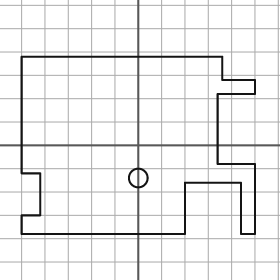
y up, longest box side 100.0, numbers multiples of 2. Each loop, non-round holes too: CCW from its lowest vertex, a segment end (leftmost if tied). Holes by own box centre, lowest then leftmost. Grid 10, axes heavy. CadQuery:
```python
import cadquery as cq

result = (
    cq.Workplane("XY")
    .moveTo(-50.0, -38.0)
    .lineTo(20.0, -38.0)
    .lineTo(20.0, -16.0)
    .lineTo(44.0, -16.0)
    .lineTo(44.0, -38.0)
    .lineTo(50.0, -38.0)
    .lineTo(50.0, -8.0)
    .lineTo(34.0, -8.0)
    .lineTo(34.0, 22.0)
    .lineTo(50.0, 22.0)
    .lineTo(50.0, 28.0)
    .lineTo(36.0, 28.0)
    .lineTo(36.0, 38.0)
    .lineTo(-50.0, 38.0)
    .lineTo(-50.0, -12.0)
    .lineTo(-42.0, -12.0)
    .lineTo(-42.0, -30.0)
    .lineTo(-50.0, -30.0)
    .close()
    .moveTo(0.0, -14.0)
    .circle(4.0)
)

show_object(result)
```